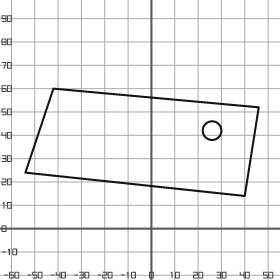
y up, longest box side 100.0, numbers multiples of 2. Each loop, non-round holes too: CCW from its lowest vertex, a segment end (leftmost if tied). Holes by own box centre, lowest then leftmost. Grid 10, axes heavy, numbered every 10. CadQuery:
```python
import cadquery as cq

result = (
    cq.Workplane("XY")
    .moveTo(40.0, 14.0)
    .lineTo(46.0, 52.0)
    .lineTo(-42.0, 60.0)
    .lineTo(-54.0, 24.0)
    .close()
    .moveTo(26.0, 42.0)
    .circle(4.0)
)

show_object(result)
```